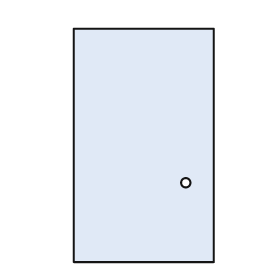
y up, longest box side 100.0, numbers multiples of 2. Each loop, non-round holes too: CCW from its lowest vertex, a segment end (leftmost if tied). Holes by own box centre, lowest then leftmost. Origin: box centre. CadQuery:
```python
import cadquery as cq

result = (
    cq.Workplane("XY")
    .moveTo(-30.0, -50.0)
    .lineTo(30.0, -50.0)
    .lineTo(30.0, 50.0)
    .lineTo(-30.0, 50.0)
    .close()
    .moveTo(18.0, -16.0)
    .circle(2.0)
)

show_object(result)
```